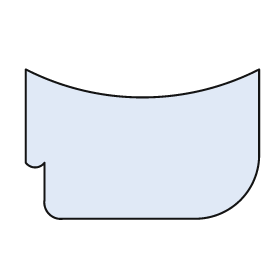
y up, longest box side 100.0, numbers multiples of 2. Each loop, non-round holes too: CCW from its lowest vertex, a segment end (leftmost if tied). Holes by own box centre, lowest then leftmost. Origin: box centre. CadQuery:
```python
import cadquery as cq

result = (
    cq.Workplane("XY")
    .moveTo(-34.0, -32.0)
    .lineTo(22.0, -32.0)
    .threePointArc((42.0, -24.0), (50.0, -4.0))
    .lineTo(50.0, 32.0)
    .threePointArc((0.0, 20.0), (-50.0, 32.0))
    .lineTo(-50.0, -8.0)
    .threePointArc((-46.0, -10.0), (-42.0, -8.0))
    .lineTo(-42.0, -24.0)
    .threePointArc((-40.0, -30.0), (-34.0, -32.0))
    .close()
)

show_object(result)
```